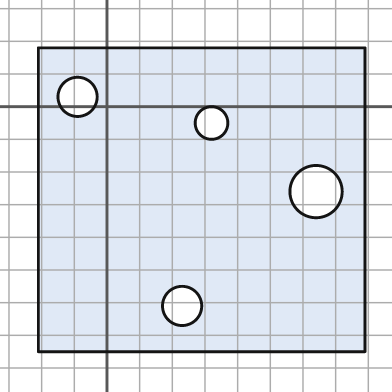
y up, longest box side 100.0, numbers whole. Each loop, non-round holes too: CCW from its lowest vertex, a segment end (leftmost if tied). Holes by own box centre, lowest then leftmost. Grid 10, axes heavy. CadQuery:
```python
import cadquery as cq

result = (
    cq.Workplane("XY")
    .moveTo(-21.0, -75.0)
    .lineTo(79.0, -75.0)
    .lineTo(79.0, 18.0)
    .lineTo(-21.0, 18.0)
    .close()
    .moveTo(23.0, -61.0)
    .circle(6.0)
    .moveTo(64.0, -26.0)
    .circle(8.0)
    .moveTo(32.0, -5.0)
    .circle(5.0)
    .moveTo(-9.0, 3.0)
    .circle(6.0)
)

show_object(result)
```